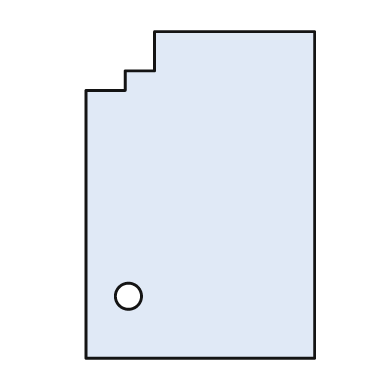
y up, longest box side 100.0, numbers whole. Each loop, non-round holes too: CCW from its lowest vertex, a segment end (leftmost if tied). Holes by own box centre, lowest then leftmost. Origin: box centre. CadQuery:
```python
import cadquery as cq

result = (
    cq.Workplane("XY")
    .moveTo(-35.0, -50.0)
    .lineTo(35.0, -50.0)
    .lineTo(35.0, 50.0)
    .lineTo(-14.0, 50.0)
    .lineTo(-14.0, 38.0)
    .lineTo(-23.0, 38.0)
    .lineTo(-23.0, 32.0)
    .lineTo(-35.0, 32.0)
    .close()
    .moveTo(-22.0, -31.0)
    .circle(4.0)
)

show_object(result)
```